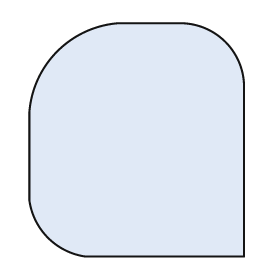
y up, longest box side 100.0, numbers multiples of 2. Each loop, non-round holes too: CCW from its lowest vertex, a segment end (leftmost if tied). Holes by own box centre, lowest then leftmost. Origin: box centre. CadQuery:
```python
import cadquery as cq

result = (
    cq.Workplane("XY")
    .moveTo(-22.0, -50.0)
    .lineTo(46.0, -50.0)
    .lineTo(46.0, 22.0)
    .threePointArc((38.0, 42.0), (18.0, 50.0))
    .lineTo(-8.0, 50.0)
    .threePointArc((-34.0, 38.0), (-46.0, 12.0))
    .lineTo(-46.0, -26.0)
    .threePointArc((-38.0, -42.0), (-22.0, -50.0))
    .close()
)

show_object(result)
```